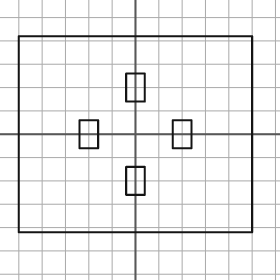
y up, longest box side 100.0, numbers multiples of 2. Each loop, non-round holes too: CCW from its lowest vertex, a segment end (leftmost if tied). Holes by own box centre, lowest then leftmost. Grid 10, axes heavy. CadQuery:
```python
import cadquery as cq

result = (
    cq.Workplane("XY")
    .moveTo(-50.0, -42.0)
    .lineTo(50.0, -42.0)
    .lineTo(50.0, 42.0)
    .lineTo(-50.0, 42.0)
    .close()
    .moveTo(-4.0, -26.0)
    .lineTo(4.0, -26.0)
    .lineTo(4.0, -14.0)
    .lineTo(-4.0, -14.0)
    .close()
    .moveTo(-24.0, -6.0)
    .lineTo(-16.0, -6.0)
    .lineTo(-16.0, 6.0)
    .lineTo(-24.0, 6.0)
    .close()
    .moveTo(16.0, -6.0)
    .lineTo(24.0, -6.0)
    .lineTo(24.0, 6.0)
    .lineTo(16.0, 6.0)
    .close()
    .moveTo(-4.0, 14.0)
    .lineTo(4.0, 14.0)
    .lineTo(4.0, 26.0)
    .lineTo(-4.0, 26.0)
    .close()
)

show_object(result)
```